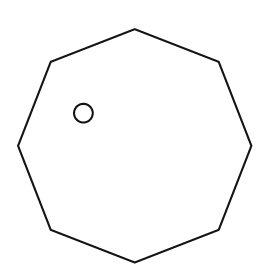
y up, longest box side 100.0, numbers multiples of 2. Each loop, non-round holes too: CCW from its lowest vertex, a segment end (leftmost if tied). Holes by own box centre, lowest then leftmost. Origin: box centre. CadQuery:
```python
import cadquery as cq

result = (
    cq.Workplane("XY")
    .moveTo(0.0, -50.0)
    .lineTo(36.0, -36.0)
    .lineTo(50.0, 0.0)
    .lineTo(36.0, 36.0)
    .lineTo(0.0, 50.0)
    .lineTo(-36.0, 36.0)
    .lineTo(-50.0, 0.0)
    .lineTo(-36.0, -36.0)
    .close()
    .moveTo(-22.0, 14.0)
    .circle(4.0)
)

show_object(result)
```